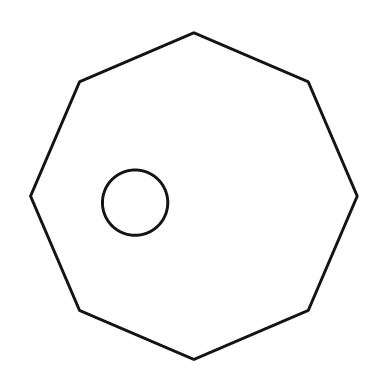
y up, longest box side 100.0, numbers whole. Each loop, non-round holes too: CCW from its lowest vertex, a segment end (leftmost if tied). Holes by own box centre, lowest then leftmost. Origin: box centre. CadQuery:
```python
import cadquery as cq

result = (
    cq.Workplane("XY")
    .moveTo(0.0, -50.0)
    .lineTo(35.0, -35.0)
    .lineTo(50.0, 0.0)
    .lineTo(35.0, 35.0)
    .lineTo(0.0, 50.0)
    .lineTo(-35.0, 35.0)
    .lineTo(-50.0, 0.0)
    .lineTo(-35.0, -35.0)
    .close()
    .moveTo(-18.0, -2.0)
    .circle(10.0)
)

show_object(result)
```